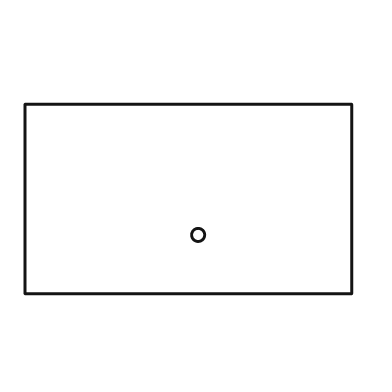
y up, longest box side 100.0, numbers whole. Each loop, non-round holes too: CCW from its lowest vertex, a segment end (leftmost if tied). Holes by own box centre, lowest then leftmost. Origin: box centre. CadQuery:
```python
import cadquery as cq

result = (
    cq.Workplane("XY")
    .moveTo(-50.0, -29.0)
    .lineTo(50.0, -29.0)
    .lineTo(50.0, 29.0)
    .lineTo(-50.0, 29.0)
    .close()
    .moveTo(3.0, -11.0)
    .circle(2.0)
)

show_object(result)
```